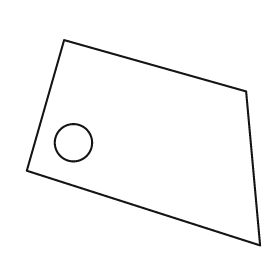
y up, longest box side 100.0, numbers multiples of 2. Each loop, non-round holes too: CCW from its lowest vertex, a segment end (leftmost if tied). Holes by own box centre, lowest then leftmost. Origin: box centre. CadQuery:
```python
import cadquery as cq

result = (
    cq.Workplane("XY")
    .moveTo(50.0, -44.0)
    .lineTo(44.0, 22.0)
    .lineTo(-34.0, 44.0)
    .lineTo(-50.0, -12.0)
    .close()
    .moveTo(-30.0, 0.0)
    .circle(8.0)
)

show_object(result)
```